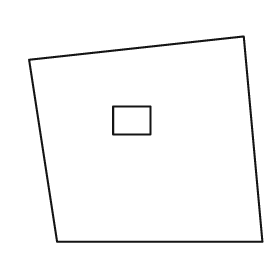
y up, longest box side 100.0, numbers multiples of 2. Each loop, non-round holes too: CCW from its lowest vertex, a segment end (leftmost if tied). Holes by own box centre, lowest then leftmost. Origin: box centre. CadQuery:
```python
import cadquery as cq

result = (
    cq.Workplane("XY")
    .moveTo(-38.0, -44.0)
    .lineTo(50.0, -44.0)
    .lineTo(42.0, 44.0)
    .lineTo(-50.0, 34.0)
    .close()
    .moveTo(-14.0, 2.0)
    .lineTo(2.0, 2.0)
    .lineTo(2.0, 14.0)
    .lineTo(-14.0, 14.0)
    .close()
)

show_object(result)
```